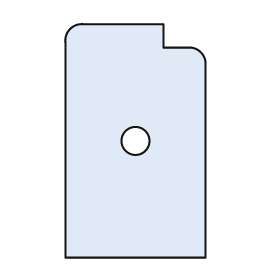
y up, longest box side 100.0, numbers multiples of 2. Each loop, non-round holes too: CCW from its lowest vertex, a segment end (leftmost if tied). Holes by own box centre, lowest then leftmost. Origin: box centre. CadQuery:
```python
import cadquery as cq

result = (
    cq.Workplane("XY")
    .moveTo(-30.0, -50.0)
    .lineTo(30.0, -50.0)
    .lineTo(30.0, 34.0)
    .threePointArc((28.0, 38.0), (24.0, 40.0))
    .lineTo(12.0, 40.0)
    .lineTo(12.0, 50.0)
    .lineTo(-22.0, 50.0)
    .threePointArc((-28.0, 48.0), (-30.0, 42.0))
    .close()
    .moveTo(0.0, 0.0)
    .circle(6.0)
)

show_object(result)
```